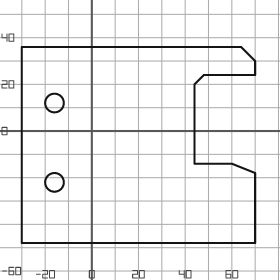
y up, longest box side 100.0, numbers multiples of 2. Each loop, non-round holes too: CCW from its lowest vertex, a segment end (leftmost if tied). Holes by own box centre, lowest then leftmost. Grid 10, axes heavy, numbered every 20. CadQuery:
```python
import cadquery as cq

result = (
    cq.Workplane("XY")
    .moveTo(-30.0, -48.0)
    .lineTo(70.0, -48.0)
    .lineTo(70.0, -18.0)
    .lineTo(60.0, -14.0)
    .lineTo(44.0, -14.0)
    .lineTo(44.0, 20.0)
    .lineTo(48.0, 24.0)
    .lineTo(70.0, 24.0)
    .lineTo(70.0, 30.0)
    .lineTo(64.0, 36.0)
    .lineTo(-30.0, 36.0)
    .close()
    .moveTo(-16.0, -22.0)
    .circle(4.0)
    .moveTo(-16.0, 12.0)
    .circle(4.0)
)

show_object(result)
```